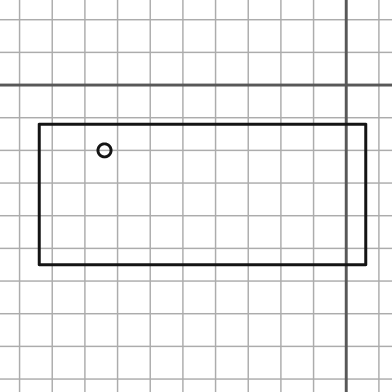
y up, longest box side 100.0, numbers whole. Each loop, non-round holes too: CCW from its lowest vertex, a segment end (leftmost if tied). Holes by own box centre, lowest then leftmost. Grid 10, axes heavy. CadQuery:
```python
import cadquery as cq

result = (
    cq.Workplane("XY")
    .moveTo(-94.0, -55.0)
    .lineTo(6.0, -55.0)
    .lineTo(6.0, -12.0)
    .lineTo(-94.0, -12.0)
    .close()
    .moveTo(-74.0, -20.0)
    .circle(2.0)
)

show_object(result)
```